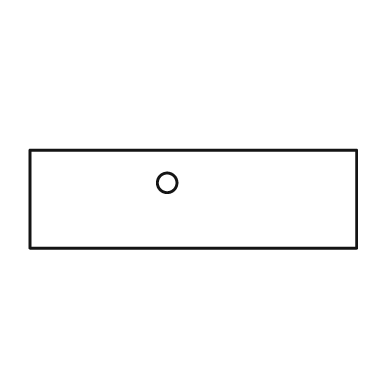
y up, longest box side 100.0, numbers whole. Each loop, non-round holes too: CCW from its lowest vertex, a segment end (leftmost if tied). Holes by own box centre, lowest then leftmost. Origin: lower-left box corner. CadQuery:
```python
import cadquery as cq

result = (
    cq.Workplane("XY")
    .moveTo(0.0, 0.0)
    .lineTo(100.0, 0.0)
    .lineTo(100.0, 30.0)
    .lineTo(0.0, 30.0)
    .close()
    .moveTo(42.0, 20.0)
    .circle(3.0)
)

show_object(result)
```